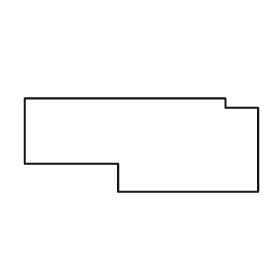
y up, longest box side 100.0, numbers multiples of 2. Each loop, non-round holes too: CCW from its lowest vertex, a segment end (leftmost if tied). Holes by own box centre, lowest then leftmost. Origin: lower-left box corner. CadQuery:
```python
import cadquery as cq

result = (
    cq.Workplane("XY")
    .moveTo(40.0, 0.0)
    .lineTo(100.0, 0.0)
    .lineTo(100.0, 36.0)
    .lineTo(86.0, 36.0)
    .lineTo(86.0, 40.0)
    .lineTo(0.0, 40.0)
    .lineTo(0.0, 12.0)
    .lineTo(40.0, 12.0)
    .close()
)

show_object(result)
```